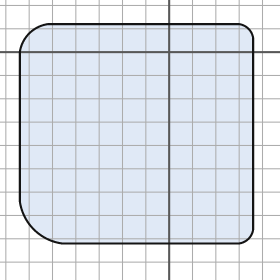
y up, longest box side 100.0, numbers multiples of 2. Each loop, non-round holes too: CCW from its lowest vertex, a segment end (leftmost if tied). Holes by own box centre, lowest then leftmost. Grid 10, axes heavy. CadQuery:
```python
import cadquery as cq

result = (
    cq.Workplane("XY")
    .moveTo(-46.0, -82.0)
    .lineTo(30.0, -82.0)
    .threePointArc((34.0, -80.0), (36.0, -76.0))
    .lineTo(36.0, 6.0)
    .threePointArc((34.0, 10.0), (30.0, 12.0))
    .lineTo(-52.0, 12.0)
    .threePointArc((-60.0, 8.0), (-64.0, 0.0))
    .lineTo(-64.0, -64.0)
    .threePointArc((-58.0, -76.0), (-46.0, -82.0))
    .close()
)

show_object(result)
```